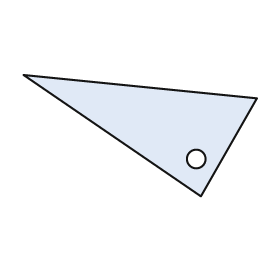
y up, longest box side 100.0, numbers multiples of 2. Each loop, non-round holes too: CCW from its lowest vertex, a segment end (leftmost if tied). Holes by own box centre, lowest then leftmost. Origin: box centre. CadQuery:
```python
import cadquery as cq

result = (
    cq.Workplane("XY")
    .moveTo(26.0, -26.0)
    .lineTo(50.0, 16.0)
    .lineTo(-50.0, 26.0)
    .close()
    .moveTo(24.0, -10.0)
    .circle(4.0)
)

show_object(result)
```